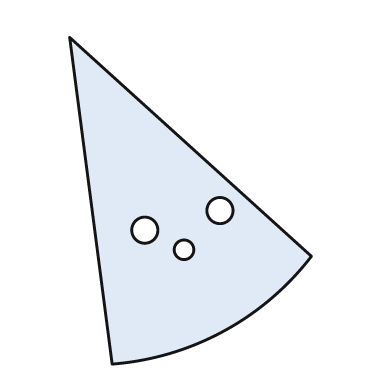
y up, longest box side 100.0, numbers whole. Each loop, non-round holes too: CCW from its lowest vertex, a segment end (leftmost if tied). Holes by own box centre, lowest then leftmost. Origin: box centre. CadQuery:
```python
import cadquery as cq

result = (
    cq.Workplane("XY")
    .moveTo(-24.0, -50.0)
    .threePointArc((10.0, -40.0), (37.0, -17.0))
    .lineTo(-37.0, 50.0)
    .close()
    .moveTo(-2.0, -15.0)
    .circle(3.0)
    .moveTo(-14.0, -9.0)
    .circle(4.0)
    .moveTo(9.0, -3.0)
    .circle(4.0)
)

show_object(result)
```